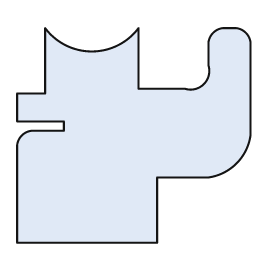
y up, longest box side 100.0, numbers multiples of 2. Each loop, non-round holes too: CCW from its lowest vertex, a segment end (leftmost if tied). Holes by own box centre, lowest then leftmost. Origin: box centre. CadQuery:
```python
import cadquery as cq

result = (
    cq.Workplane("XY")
    .moveTo(-50.0, -46.0)
    .lineTo(10.0, -46.0)
    .lineTo(10.0, -18.0)
    .lineTo(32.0, -18.0)
    .threePointArc((44.0, -12.0), (50.0, 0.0))
    .lineTo(50.0, 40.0)
    .threePointArc((48.0, 44.0), (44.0, 46.0))
    .lineTo(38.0, 46.0)
    .threePointArc((34.0, 44.0), (32.0, 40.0))
    .lineTo(32.0, 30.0)
    .threePointArc((30.0, 22.0), (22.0, 20.0))
    .lineTo(2.0, 20.0)
    .lineTo(2.0, 46.0)
    .threePointArc((-18.0, 36.0), (-38.0, 46.0))
    .lineTo(-38.0, 18.0)
    .lineTo(-50.0, 18.0)
    .lineTo(-50.0, 6.0)
    .lineTo(-30.0, 6.0)
    .lineTo(-30.0, 2.0)
    .lineTo(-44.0, 2.0)
    .threePointArc((-48.0, 0.0), (-50.0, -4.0))
    .close()
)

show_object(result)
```